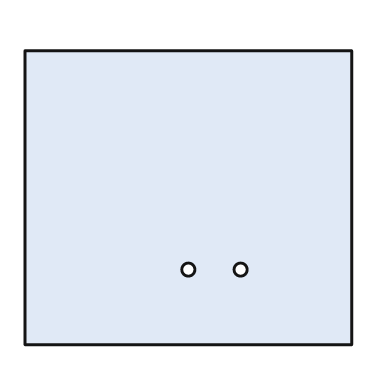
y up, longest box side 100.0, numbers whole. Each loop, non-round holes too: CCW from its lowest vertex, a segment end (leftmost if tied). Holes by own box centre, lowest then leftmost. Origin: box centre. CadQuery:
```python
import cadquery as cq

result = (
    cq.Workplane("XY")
    .moveTo(-50.0, -45.0)
    .lineTo(50.0, -45.0)
    .lineTo(50.0, 45.0)
    .lineTo(-50.0, 45.0)
    .close()
    .moveTo(0.0, -22.0)
    .circle(2.0)
    .moveTo(16.0, -22.0)
    .circle(2.0)
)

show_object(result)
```